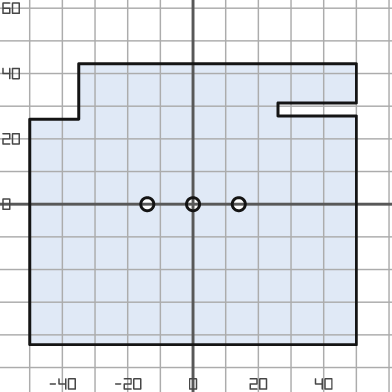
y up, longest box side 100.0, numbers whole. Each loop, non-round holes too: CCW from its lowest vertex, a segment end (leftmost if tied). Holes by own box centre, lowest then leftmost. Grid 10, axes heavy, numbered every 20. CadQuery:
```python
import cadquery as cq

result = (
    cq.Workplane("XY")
    .moveTo(-50.0, -43.0)
    .lineTo(50.0, -43.0)
    .lineTo(50.0, 27.0)
    .lineTo(26.0, 27.0)
    .lineTo(26.0, 31.0)
    .lineTo(50.0, 31.0)
    .lineTo(50.0, 43.0)
    .lineTo(-35.0, 43.0)
    .lineTo(-35.0, 26.0)
    .lineTo(-50.0, 26.0)
    .close()
    .moveTo(-14.0, 0.0)
    .circle(2.0)
    .moveTo(0.0, 0.0)
    .circle(2.0)
    .moveTo(14.0, 0.0)
    .circle(2.0)
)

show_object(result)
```